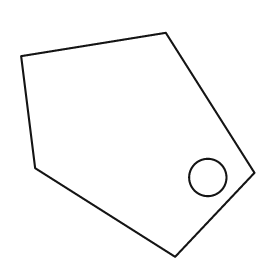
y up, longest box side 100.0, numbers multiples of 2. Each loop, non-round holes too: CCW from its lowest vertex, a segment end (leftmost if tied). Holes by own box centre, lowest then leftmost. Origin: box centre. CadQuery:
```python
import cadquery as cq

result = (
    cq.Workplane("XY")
    .moveTo(16.0, -48.0)
    .lineTo(50.0, -12.0)
    .lineTo(12.0, 48.0)
    .lineTo(-50.0, 38.0)
    .lineTo(-44.0, -10.0)
    .close()
    .moveTo(30.0, -14.0)
    .circle(8.0)
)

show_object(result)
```